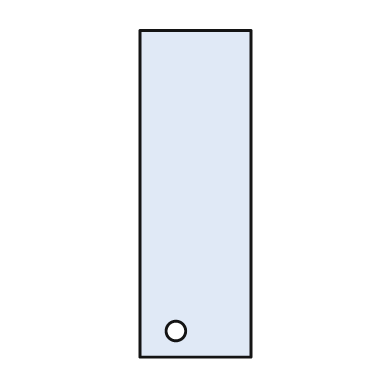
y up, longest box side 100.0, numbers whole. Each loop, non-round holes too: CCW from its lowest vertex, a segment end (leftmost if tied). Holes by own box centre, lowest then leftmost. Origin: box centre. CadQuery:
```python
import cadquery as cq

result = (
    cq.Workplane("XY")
    .moveTo(-17.0, -50.0)
    .lineTo(17.0, -50.0)
    .lineTo(17.0, 50.0)
    .lineTo(-17.0, 50.0)
    .close()
    .moveTo(-6.0, -42.0)
    .circle(3.0)
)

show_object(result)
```